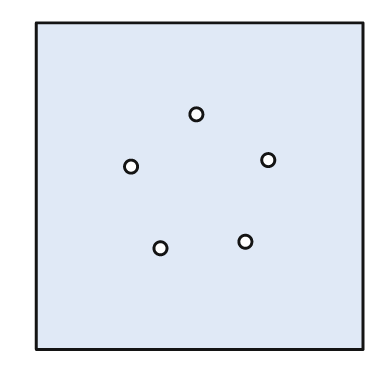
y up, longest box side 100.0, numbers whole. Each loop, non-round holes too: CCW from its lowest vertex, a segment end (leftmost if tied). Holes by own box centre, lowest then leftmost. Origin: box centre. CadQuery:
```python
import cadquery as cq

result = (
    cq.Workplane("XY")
    .moveTo(-50.0, -50.0)
    .lineTo(50.0, -50.0)
    .lineTo(50.0, 50.0)
    .lineTo(-50.0, 50.0)
    .close()
    .moveTo(-12.0, -19.0)
    .circle(2.0)
    .moveTo(14.0, -17.0)
    .circle(2.0)
    .moveTo(-21.0, 6.0)
    .circle(2.0)
    .moveTo(21.0, 8.0)
    .circle(2.0)
    .moveTo(-1.0, 22.0)
    .circle(2.0)
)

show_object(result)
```